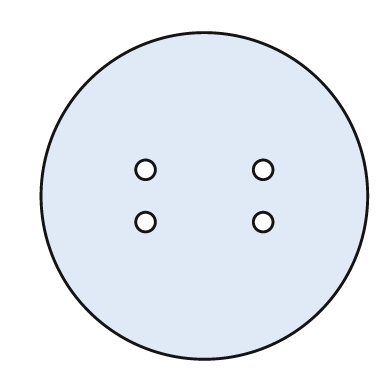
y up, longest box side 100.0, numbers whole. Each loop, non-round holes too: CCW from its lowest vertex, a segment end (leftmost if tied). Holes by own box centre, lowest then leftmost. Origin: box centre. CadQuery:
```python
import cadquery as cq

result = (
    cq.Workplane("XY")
    .moveTo(0.0, 0.0)
    .circle(50.0)
    .moveTo(-18.0, -8.0)
    .circle(3.0)
    .moveTo(18.0, -8.0)
    .circle(3.0)
    .moveTo(-18.0, 8.0)
    .circle(3.0)
    .moveTo(18.0, 8.0)
    .circle(3.0)
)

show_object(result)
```